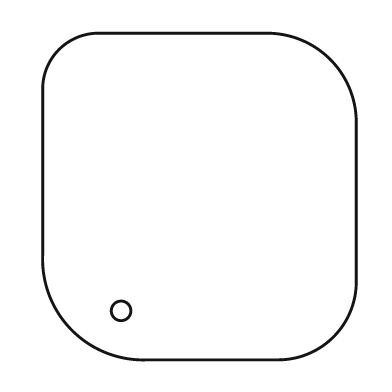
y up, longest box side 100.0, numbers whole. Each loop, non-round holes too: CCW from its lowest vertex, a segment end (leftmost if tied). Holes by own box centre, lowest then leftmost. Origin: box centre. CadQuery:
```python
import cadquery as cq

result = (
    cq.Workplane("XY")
    .moveTo(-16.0, -50.0)
    .lineTo(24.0, -50.0)
    .threePointArc((41.0, -43.0), (48.0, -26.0))
    .lineTo(48.0, 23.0)
    .threePointArc((40.0, 42.0), (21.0, 50.0))
    .lineTo(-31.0, 50.0)
    .threePointArc((-43.0, 45.0), (-48.0, 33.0))
    .lineTo(-48.0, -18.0)
    .threePointArc((-39.0, -41.0), (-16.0, -50.0))
    .close()
    .moveTo(-24.0, -35.0)
    .circle(3.0)
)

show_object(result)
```